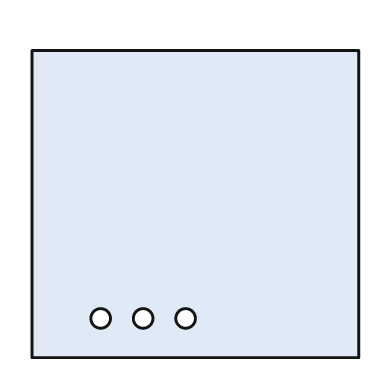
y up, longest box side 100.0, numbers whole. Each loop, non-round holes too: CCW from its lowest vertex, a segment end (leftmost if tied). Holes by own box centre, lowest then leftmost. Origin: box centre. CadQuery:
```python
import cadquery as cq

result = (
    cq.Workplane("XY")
    .moveTo(-50.0, -47.0)
    .lineTo(50.0, -47.0)
    .lineTo(50.0, 47.0)
    .lineTo(-50.0, 47.0)
    .close()
    .moveTo(-29.0, -35.0)
    .circle(3.0)
    .moveTo(-16.0, -35.0)
    .circle(3.0)
    .moveTo(-3.0, -35.0)
    .circle(3.0)
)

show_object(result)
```